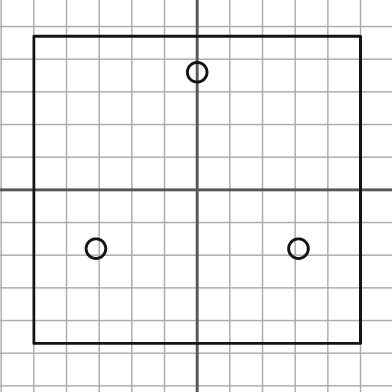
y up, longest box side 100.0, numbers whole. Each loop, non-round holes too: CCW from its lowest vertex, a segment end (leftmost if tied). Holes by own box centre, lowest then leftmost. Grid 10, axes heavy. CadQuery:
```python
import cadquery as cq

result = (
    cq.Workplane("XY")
    .moveTo(-50.0, -47.0)
    .lineTo(50.0, -47.0)
    .lineTo(50.0, 47.0)
    .lineTo(-50.0, 47.0)
    .close()
    .moveTo(-31.0, -18.0)
    .circle(3.0)
    .moveTo(31.0, -18.0)
    .circle(3.0)
    .moveTo(0.0, 36.0)
    .circle(3.0)
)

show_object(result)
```